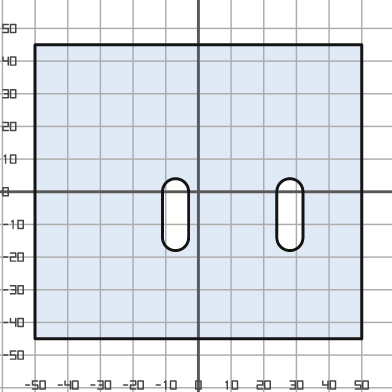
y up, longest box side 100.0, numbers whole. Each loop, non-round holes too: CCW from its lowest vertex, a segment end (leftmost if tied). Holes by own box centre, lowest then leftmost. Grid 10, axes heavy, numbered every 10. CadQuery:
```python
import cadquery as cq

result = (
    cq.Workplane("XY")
    .moveTo(-50.0, -45.0)
    .lineTo(50.0, -45.0)
    .lineTo(50.0, 45.0)
    .lineTo(-50.0, 45.0)
    .close()
    .moveTo(-11.0, -14.0)
    .threePointArc((-7.0, -18.0), (-3.0, -14.0))
    .lineTo(-3.0, 0.0)
    .threePointArc((-7.0, 4.0), (-11.0, 0.0))
    .close()
    .moveTo(24.0, -14.0)
    .threePointArc((28.0, -18.0), (32.0, -14.0))
    .lineTo(32.0, 0.0)
    .threePointArc((28.0, 4.0), (24.0, 0.0))
    .close()
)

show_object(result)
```